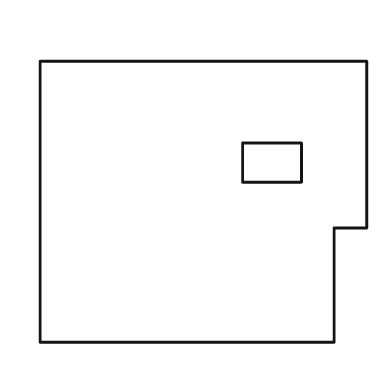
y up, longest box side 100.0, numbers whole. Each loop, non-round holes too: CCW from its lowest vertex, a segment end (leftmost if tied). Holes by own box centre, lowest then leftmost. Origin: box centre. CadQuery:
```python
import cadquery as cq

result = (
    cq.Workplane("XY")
    .moveTo(-50.0, -43.0)
    .lineTo(40.0, -43.0)
    .lineTo(40.0, -8.0)
    .lineTo(50.0, -8.0)
    .lineTo(50.0, 43.0)
    .lineTo(-50.0, 43.0)
    .close()
    .moveTo(12.0, 6.0)
    .lineTo(30.0, 6.0)
    .lineTo(30.0, 18.0)
    .lineTo(12.0, 18.0)
    .close()
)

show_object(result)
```